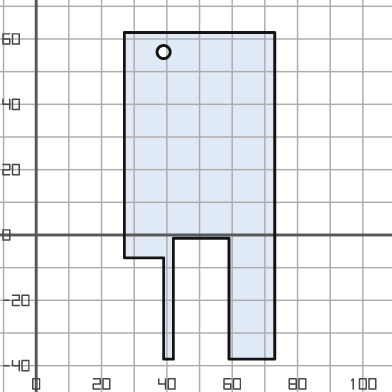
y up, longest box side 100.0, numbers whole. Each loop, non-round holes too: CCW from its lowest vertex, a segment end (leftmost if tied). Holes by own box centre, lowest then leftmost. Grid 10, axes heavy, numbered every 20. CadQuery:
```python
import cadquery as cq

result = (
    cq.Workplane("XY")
    .moveTo(39.0, -38.0)
    .lineTo(42.0, -38.0)
    .lineTo(42.0, -1.0)
    .lineTo(59.0, -1.0)
    .lineTo(59.0, -38.0)
    .lineTo(73.0, -38.0)
    .lineTo(73.0, 62.0)
    .lineTo(27.0, 62.0)
    .lineTo(27.0, -7.0)
    .lineTo(39.0, -7.0)
    .close()
    .moveTo(39.0, 56.0)
    .circle(2.0)
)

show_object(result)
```